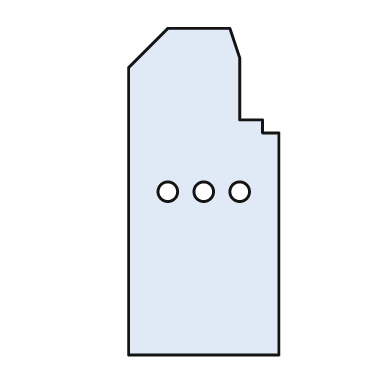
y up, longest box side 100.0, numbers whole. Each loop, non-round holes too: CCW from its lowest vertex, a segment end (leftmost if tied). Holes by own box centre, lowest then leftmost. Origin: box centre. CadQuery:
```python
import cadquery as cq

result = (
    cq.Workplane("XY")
    .moveTo(-23.0, -50.0)
    .lineTo(23.0, -50.0)
    .lineTo(23.0, 18.0)
    .lineTo(18.0, 18.0)
    .lineTo(18.0, 22.0)
    .lineTo(11.0, 22.0)
    .lineTo(11.0, 41.0)
    .lineTo(8.0, 50.0)
    .lineTo(-11.0, 50.0)
    .lineTo(-23.0, 38.0)
    .close()
    .moveTo(-11.0, 0.0)
    .circle(3.0)
    .moveTo(0.0, 0.0)
    .circle(3.0)
    .moveTo(11.0, 0.0)
    .circle(3.0)
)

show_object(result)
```